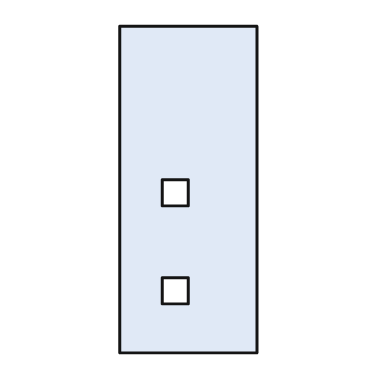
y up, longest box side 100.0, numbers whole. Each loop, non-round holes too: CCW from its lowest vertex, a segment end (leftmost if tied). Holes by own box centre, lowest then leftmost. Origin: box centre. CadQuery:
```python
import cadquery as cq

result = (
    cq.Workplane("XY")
    .moveTo(-21.0, -50.0)
    .lineTo(21.0, -50.0)
    .lineTo(21.0, 50.0)
    .lineTo(-21.0, 50.0)
    .close()
    .moveTo(-8.0, -35.0)
    .lineTo(0.0, -35.0)
    .lineTo(0.0, -27.0)
    .lineTo(-8.0, -27.0)
    .close()
    .moveTo(-8.0, -5.0)
    .lineTo(0.0, -5.0)
    .lineTo(0.0, 3.0)
    .lineTo(-8.0, 3.0)
    .close()
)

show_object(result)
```